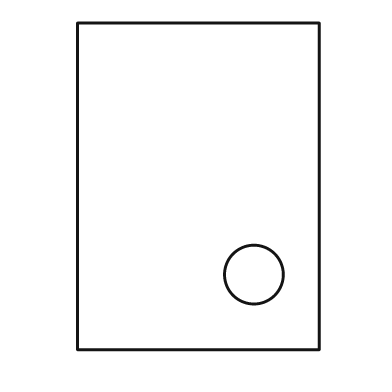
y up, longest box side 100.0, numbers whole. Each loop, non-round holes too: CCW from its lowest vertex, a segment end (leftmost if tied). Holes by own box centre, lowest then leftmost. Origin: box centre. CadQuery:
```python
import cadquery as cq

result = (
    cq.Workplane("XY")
    .moveTo(-37.0, -50.0)
    .lineTo(37.0, -50.0)
    .lineTo(37.0, 50.0)
    .lineTo(-37.0, 50.0)
    .close()
    .moveTo(17.0, -27.0)
    .circle(9.0)
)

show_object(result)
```